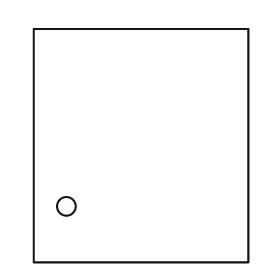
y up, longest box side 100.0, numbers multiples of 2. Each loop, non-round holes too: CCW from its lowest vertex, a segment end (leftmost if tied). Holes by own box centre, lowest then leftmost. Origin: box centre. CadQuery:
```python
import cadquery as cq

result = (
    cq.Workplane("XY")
    .moveTo(-46.0, -50.0)
    .lineTo(46.0, -50.0)
    .lineTo(46.0, 50.0)
    .lineTo(-46.0, 50.0)
    .close()
    .moveTo(-32.0, -26.0)
    .circle(4.0)
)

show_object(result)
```